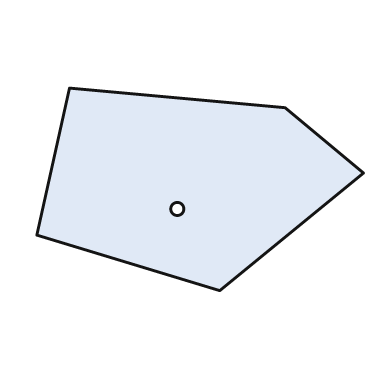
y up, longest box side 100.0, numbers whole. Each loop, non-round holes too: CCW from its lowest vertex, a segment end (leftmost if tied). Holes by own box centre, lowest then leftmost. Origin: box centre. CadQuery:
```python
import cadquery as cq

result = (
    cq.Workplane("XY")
    .moveTo(6.0, -31.0)
    .lineTo(50.0, 5.0)
    .lineTo(26.0, 25.0)
    .lineTo(-40.0, 31.0)
    .lineTo(-50.0, -14.0)
    .close()
    .moveTo(-7.0, -6.0)
    .circle(2.0)
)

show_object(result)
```